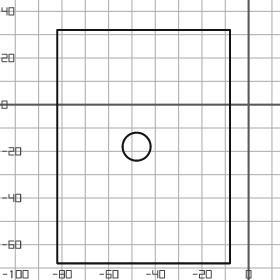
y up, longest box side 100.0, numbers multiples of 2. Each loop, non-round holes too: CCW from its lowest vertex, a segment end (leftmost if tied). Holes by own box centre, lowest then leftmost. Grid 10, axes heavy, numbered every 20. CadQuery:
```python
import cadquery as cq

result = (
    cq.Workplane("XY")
    .moveTo(-82.0, -68.0)
    .lineTo(-8.0, -68.0)
    .lineTo(-8.0, 32.0)
    .lineTo(-82.0, 32.0)
    .close()
    .moveTo(-48.0, -18.0)
    .circle(6.0)
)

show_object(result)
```